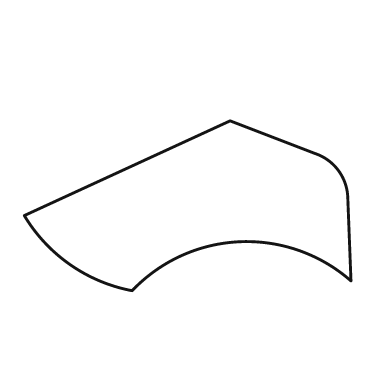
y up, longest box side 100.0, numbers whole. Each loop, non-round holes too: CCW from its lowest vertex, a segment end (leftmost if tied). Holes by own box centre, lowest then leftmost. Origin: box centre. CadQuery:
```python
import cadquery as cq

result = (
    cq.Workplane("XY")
    .moveTo(-17.0, -26.0)
    .threePointArc((16.0, -11.0), (50.0, -23.0))
    .lineTo(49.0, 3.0)
    .threePointArc((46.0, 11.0), (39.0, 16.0))
    .lineTo(13.0, 26.0)
    .lineTo(-50.0, -3.0)
    .threePointArc((-36.0, -18.0), (-17.0, -26.0))
    .close()
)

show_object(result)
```